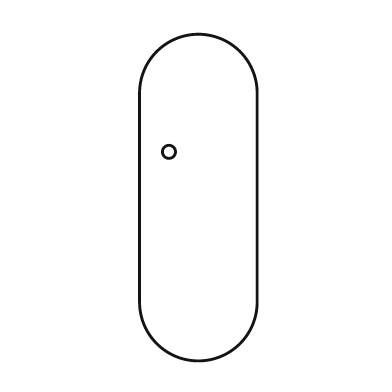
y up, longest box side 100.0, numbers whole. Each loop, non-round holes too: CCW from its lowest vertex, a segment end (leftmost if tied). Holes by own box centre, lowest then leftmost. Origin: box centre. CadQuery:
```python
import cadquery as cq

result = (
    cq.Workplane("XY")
    .moveTo(-18.0, -32.0)
    .threePointArc((0.0, -50.0), (18.0, -32.0))
    .lineTo(18.0, 32.0)
    .threePointArc((0.0, 50.0), (-18.0, 32.0))
    .close()
    .moveTo(-9.0, 14.0)
    .circle(2.0)
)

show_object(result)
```